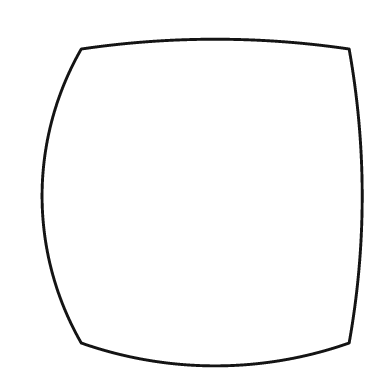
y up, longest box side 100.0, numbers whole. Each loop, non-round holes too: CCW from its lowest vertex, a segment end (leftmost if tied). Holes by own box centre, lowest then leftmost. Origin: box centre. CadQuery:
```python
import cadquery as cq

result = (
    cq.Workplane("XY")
    .moveTo(-37.0, -43.0)
    .threePointArc((4.0, -50.0), (45.0, -43.0))
    .threePointArc((49.0, 2.0), (45.0, 47.0))
    .threePointArc((4.0, 50.0), (-37.0, 47.0))
    .threePointArc((-49.0, 2.0), (-37.0, -43.0))
    .close()
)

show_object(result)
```